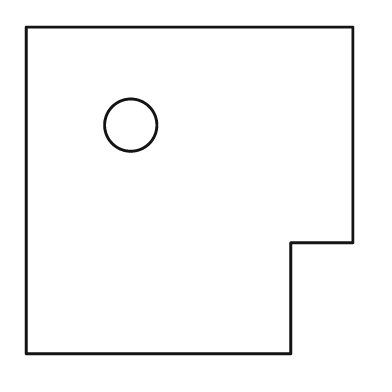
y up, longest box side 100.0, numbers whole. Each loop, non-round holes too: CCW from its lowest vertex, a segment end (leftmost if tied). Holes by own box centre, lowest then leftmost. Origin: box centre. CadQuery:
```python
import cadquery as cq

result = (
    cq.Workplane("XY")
    .moveTo(-50.0, -50.0)
    .lineTo(31.0, -50.0)
    .lineTo(31.0, -16.0)
    .lineTo(50.0, -16.0)
    .lineTo(50.0, 50.0)
    .lineTo(-50.0, 50.0)
    .close()
    .moveTo(-18.0, 20.0)
    .circle(8.0)
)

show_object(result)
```